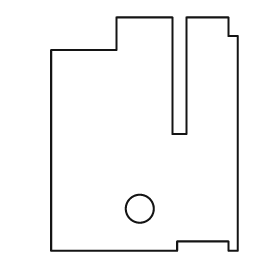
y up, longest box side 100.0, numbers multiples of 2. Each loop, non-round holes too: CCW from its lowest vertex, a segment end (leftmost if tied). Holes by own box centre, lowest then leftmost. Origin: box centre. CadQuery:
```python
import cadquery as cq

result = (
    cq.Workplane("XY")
    .moveTo(-40.0, -50.0)
    .lineTo(14.0, -50.0)
    .lineTo(14.0, -46.0)
    .lineTo(36.0, -46.0)
    .lineTo(36.0, -50.0)
    .lineTo(40.0, -50.0)
    .lineTo(40.0, 42.0)
    .lineTo(36.0, 42.0)
    .lineTo(36.0, 50.0)
    .lineTo(18.0, 50.0)
    .lineTo(18.0, 0.0)
    .lineTo(12.0, 0.0)
    .lineTo(12.0, 50.0)
    .lineTo(-12.0, 50.0)
    .lineTo(-12.0, 36.0)
    .lineTo(-40.0, 36.0)
    .close()
    .moveTo(-2.0, -32.0)
    .circle(6.0)
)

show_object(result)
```